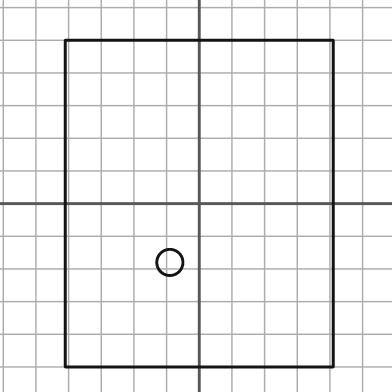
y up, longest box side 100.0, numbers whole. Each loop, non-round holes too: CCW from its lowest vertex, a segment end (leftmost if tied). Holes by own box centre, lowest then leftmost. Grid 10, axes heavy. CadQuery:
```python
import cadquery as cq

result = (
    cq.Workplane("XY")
    .moveTo(-41.0, -50.0)
    .lineTo(41.0, -50.0)
    .lineTo(41.0, 50.0)
    .lineTo(-41.0, 50.0)
    .close()
    .moveTo(-9.0, -18.0)
    .circle(4.0)
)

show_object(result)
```